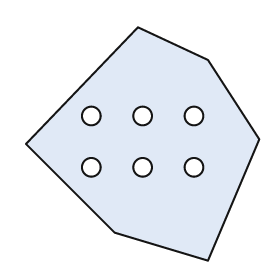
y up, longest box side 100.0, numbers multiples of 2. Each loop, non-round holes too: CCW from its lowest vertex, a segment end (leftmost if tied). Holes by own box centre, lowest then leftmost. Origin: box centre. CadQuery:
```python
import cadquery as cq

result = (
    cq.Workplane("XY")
    .moveTo(28.0, -50.0)
    .lineTo(50.0, 2.0)
    .lineTo(28.0, 36.0)
    .lineTo(-2.0, 50.0)
    .lineTo(-50.0, 0.0)
    .lineTo(-12.0, -38.0)
    .close()
    .moveTo(-22.0, -10.0)
    .circle(4.0)
    .moveTo(0.0, -10.0)
    .circle(4.0)
    .moveTo(22.0, -10.0)
    .circle(4.0)
    .moveTo(-22.0, 12.0)
    .circle(4.0)
    .moveTo(0.0, 12.0)
    .circle(4.0)
    .moveTo(22.0, 12.0)
    .circle(4.0)
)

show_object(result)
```